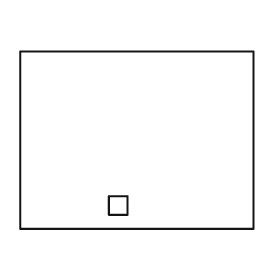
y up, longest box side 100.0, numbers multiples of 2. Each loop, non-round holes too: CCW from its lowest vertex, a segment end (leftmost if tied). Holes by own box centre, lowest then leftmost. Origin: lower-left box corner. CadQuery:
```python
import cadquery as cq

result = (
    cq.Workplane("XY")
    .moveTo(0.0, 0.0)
    .lineTo(100.0, 0.0)
    .lineTo(100.0, 76.0)
    .lineTo(0.0, 76.0)
    .close()
    .moveTo(38.0, 6.0)
    .lineTo(46.0, 6.0)
    .lineTo(46.0, 14.0)
    .lineTo(38.0, 14.0)
    .close()
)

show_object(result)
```